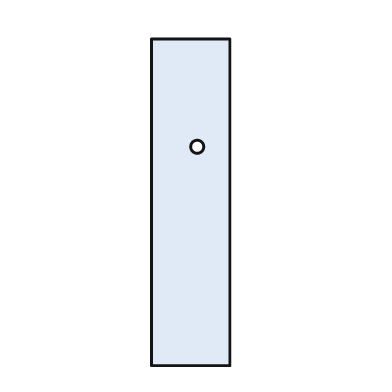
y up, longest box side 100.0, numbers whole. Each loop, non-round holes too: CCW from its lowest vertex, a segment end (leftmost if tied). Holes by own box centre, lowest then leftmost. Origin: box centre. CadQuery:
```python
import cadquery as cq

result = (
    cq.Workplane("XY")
    .moveTo(-12.0, -50.0)
    .lineTo(12.0, -50.0)
    .lineTo(12.0, 50.0)
    .lineTo(-12.0, 50.0)
    .close()
    .moveTo(2.0, 17.0)
    .circle(2.0)
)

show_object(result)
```